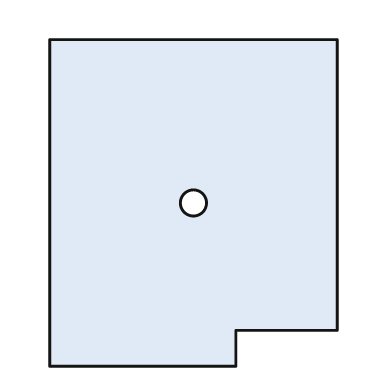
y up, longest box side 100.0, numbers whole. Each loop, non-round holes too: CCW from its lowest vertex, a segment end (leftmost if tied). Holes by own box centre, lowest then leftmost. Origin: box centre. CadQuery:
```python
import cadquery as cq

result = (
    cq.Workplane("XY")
    .moveTo(-44.0, -50.0)
    .lineTo(13.0, -50.0)
    .lineTo(13.0, -39.0)
    .lineTo(44.0, -39.0)
    .lineTo(44.0, 50.0)
    .lineTo(-44.0, 50.0)
    .close()
    .moveTo(0.0, 0.0)
    .circle(4.0)
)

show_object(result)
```